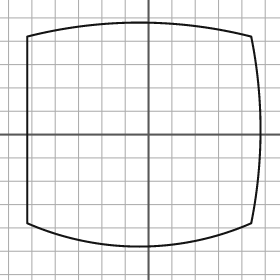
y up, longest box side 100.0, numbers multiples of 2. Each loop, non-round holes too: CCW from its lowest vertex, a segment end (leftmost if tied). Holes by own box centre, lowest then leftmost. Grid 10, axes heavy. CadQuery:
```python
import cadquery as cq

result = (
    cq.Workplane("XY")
    .moveTo(-52.0, -38.0)
    .threePointArc((-4.0, -48.0), (44.0, -38.0))
    .threePointArc((48.0, 2.0), (44.0, 42.0))
    .threePointArc((-4.0, 48.0), (-52.0, 42.0))
    .close()
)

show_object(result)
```